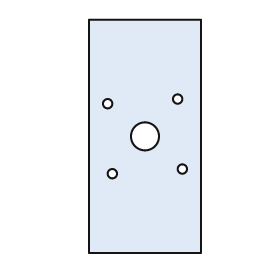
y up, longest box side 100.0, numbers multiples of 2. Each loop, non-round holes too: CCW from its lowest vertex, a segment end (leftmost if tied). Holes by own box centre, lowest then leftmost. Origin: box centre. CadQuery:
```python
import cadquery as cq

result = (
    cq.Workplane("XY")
    .moveTo(-24.0, -50.0)
    .lineTo(24.0, -50.0)
    .lineTo(24.0, 50.0)
    .lineTo(-24.0, 50.0)
    .close()
    .moveTo(-14.0, -16.0)
    .circle(2.0)
    .moveTo(16.0, -14.0)
    .circle(2.0)
    .moveTo(0.0, 0.0)
    .circle(6.0)
    .moveTo(-16.0, 14.0)
    .circle(2.0)
    .moveTo(14.0, 16.0)
    .circle(2.0)
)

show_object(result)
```